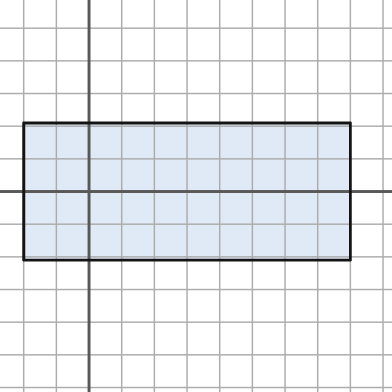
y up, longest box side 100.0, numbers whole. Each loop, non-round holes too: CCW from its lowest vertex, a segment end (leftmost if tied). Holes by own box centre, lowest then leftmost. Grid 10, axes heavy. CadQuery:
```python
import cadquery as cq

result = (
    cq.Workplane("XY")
    .moveTo(-20.0, -21.0)
    .lineTo(80.0, -21.0)
    .lineTo(80.0, 21.0)
    .lineTo(-20.0, 21.0)
    .close()
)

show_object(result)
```